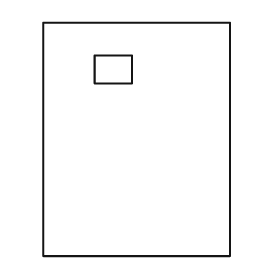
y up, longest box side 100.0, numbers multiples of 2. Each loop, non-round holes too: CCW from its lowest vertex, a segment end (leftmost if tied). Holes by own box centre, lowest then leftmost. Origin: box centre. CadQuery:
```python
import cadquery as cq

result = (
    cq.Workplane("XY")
    .moveTo(-40.0, -50.0)
    .lineTo(40.0, -50.0)
    .lineTo(40.0, 50.0)
    .lineTo(-40.0, 50.0)
    .close()
    .moveTo(-18.0, 24.0)
    .lineTo(-2.0, 24.0)
    .lineTo(-2.0, 36.0)
    .lineTo(-18.0, 36.0)
    .close()
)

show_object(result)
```